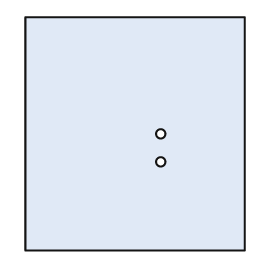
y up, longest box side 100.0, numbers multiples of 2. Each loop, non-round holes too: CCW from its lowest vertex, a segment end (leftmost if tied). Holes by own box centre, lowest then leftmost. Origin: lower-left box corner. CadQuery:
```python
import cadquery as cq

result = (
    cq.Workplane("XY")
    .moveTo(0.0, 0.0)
    .lineTo(94.0, 0.0)
    .lineTo(94.0, 100.0)
    .lineTo(0.0, 100.0)
    .close()
    .moveTo(58.0, 38.0)
    .circle(2.0)
    .moveTo(58.0, 50.0)
    .circle(2.0)
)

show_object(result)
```